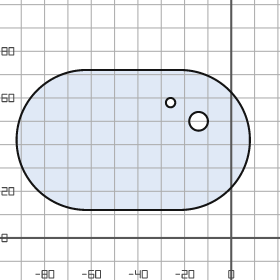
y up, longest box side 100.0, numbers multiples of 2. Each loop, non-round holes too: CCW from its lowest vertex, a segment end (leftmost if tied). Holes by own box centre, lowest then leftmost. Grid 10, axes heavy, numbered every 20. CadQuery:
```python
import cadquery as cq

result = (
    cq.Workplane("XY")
    .moveTo(-62.0, 12.0)
    .lineTo(-22.0, 12.0)
    .threePointArc((8.0, 42.0), (-22.0, 72.0))
    .lineTo(-62.0, 72.0)
    .threePointArc((-92.0, 42.0), (-62.0, 12.0))
    .close()
    .moveTo(-14.0, 50.0)
    .circle(4.0)
    .moveTo(-26.0, 58.0)
    .circle(2.0)
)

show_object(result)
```